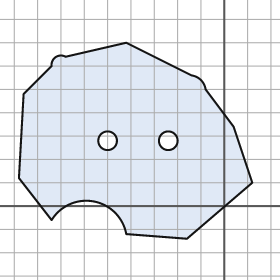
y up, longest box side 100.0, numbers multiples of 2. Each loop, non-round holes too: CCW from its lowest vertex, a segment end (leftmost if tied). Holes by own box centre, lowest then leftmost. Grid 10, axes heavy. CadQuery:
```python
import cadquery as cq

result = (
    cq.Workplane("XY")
    .moveTo(-16.0, -14.0)
    .lineTo(12.0, 10.0)
    .lineTo(4.0, 34.0)
    .lineTo(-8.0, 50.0)
    .threePointArc((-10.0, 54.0), (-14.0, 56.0))
    .lineTo(-42.0, 70.0)
    .lineTo(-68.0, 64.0)
    .threePointArc((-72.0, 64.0), (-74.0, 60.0))
    .lineTo(-86.0, 48.0)
    .lineTo(-88.0, 12.0)
    .lineTo(-74.0, -6.0)
    .threePointArc((-56.0, 2.0), (-42.0, -12.0))
    .close()
    .moveTo(-50.0, 28.0)
    .circle(4.0)
    .moveTo(-24.0, 28.0)
    .circle(4.0)
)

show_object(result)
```